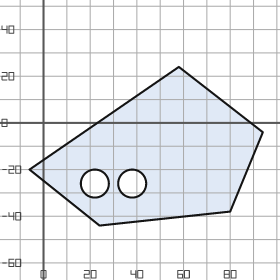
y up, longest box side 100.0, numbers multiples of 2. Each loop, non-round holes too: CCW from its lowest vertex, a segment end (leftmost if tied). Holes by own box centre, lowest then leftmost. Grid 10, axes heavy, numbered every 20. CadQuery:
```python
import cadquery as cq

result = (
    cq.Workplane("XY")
    .moveTo(24.0, -44.0)
    .lineTo(80.0, -38.0)
    .lineTo(94.0, -4.0)
    .lineTo(58.0, 24.0)
    .lineTo(-6.0, -20.0)
    .close()
    .moveTo(22.0, -26.0)
    .circle(6.0)
    .moveTo(38.0, -26.0)
    .circle(6.0)
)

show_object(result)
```